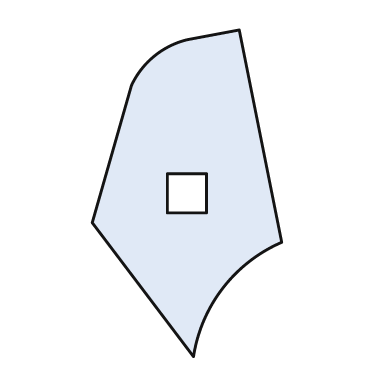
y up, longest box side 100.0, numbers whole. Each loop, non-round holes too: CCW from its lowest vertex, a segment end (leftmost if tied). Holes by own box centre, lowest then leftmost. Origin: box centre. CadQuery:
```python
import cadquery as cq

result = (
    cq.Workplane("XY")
    .moveTo(2.0, -50.0)
    .threePointArc((11.0, -29.0), (29.0, -15.0))
    .lineTo(16.0, 50.0)
    .lineTo(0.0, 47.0)
    .threePointArc((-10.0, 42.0), (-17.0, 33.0))
    .lineTo(-29.0, -9.0)
    .close()
    .moveTo(-6.0, -6.0)
    .lineTo(6.0, -6.0)
    .lineTo(6.0, 6.0)
    .lineTo(-6.0, 6.0)
    .close()
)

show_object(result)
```